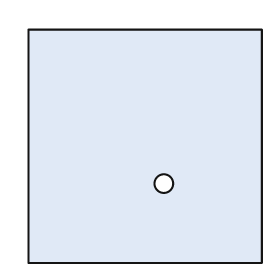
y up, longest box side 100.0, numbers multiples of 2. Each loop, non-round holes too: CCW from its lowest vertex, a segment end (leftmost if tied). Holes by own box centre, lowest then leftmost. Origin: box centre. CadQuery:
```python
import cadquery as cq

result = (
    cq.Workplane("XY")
    .moveTo(-50.0, -50.0)
    .lineTo(50.0, -50.0)
    .lineTo(50.0, 50.0)
    .lineTo(-50.0, 50.0)
    .close()
    .moveTo(8.0, -16.0)
    .circle(4.0)
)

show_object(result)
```